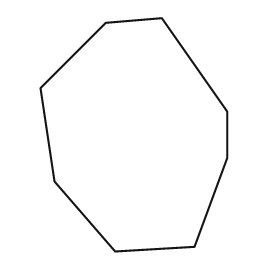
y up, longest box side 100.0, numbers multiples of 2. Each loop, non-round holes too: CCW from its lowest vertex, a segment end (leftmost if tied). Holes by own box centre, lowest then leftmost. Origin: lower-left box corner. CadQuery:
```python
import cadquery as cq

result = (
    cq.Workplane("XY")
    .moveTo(32.0, 0.0)
    .lineTo(66.0, 2.0)
    .lineTo(80.0, 40.0)
    .lineTo(80.0, 60.0)
    .lineTo(52.0, 100.0)
    .lineTo(28.0, 98.0)
    .lineTo(0.0, 70.0)
    .lineTo(6.0, 30.0)
    .close()
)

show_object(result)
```